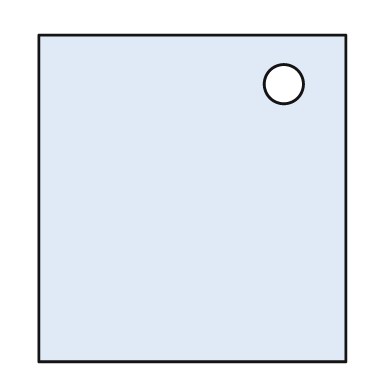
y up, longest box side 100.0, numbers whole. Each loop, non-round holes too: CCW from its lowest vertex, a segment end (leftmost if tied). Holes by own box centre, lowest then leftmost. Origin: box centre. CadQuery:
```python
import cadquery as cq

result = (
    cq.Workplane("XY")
    .moveTo(-47.0, -50.0)
    .lineTo(47.0, -50.0)
    .lineTo(47.0, 50.0)
    .lineTo(-47.0, 50.0)
    .close()
    .moveTo(28.0, 35.0)
    .circle(6.0)
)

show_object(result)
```